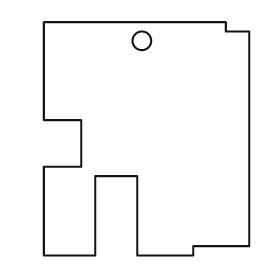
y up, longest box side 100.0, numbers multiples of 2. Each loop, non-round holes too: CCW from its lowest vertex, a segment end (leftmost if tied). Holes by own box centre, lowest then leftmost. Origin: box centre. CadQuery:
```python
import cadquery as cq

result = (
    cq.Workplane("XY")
    .moveTo(-44.0, -50.0)
    .lineTo(-22.0, -50.0)
    .lineTo(-22.0, -16.0)
    .lineTo(-4.0, -16.0)
    .lineTo(-4.0, -50.0)
    .lineTo(20.0, -50.0)
    .lineTo(20.0, -46.0)
    .lineTo(44.0, -46.0)
    .lineTo(44.0, 46.0)
    .lineTo(34.0, 46.0)
    .lineTo(34.0, 50.0)
    .lineTo(-44.0, 50.0)
    .lineTo(-44.0, 8.0)
    .lineTo(-28.0, 8.0)
    .lineTo(-28.0, -12.0)
    .lineTo(-44.0, -12.0)
    .close()
    .moveTo(-2.0, 42.0)
    .circle(4.0)
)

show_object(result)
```